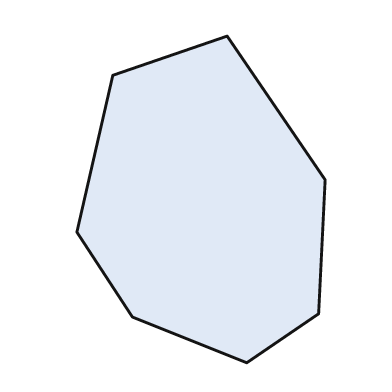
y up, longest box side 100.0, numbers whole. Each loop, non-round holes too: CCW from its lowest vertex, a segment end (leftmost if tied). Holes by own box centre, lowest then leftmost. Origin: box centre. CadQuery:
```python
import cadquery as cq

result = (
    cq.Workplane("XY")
    .moveTo(14.0, -50.0)
    .lineTo(36.0, -35.0)
    .lineTo(38.0, 6.0)
    .lineTo(8.0, 50.0)
    .lineTo(-27.0, 38.0)
    .lineTo(-38.0, -10.0)
    .lineTo(-21.0, -36.0)
    .close()
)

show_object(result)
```